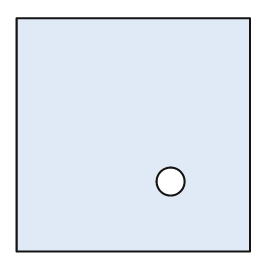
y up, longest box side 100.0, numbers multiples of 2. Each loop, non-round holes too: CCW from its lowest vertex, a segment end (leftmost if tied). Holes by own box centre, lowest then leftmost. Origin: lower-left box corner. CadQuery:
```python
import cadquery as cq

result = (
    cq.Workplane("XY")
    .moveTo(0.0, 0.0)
    .lineTo(100.0, 0.0)
    .lineTo(100.0, 100.0)
    .lineTo(0.0, 100.0)
    .close()
    .moveTo(66.0, 30.0)
    .circle(6.0)
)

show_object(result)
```